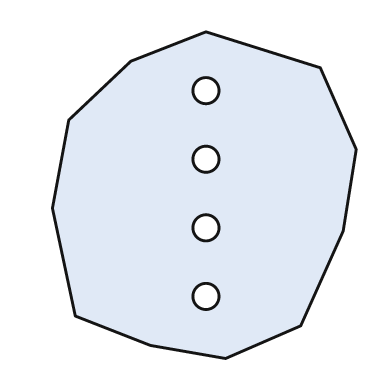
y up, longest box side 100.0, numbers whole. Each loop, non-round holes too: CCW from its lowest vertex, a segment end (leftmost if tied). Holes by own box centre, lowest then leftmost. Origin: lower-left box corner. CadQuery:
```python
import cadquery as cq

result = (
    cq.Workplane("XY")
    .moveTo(53.0, 0.0)
    .lineTo(76.0, 10.0)
    .lineTo(89.0, 39.0)
    .lineTo(93.0, 64.0)
    .lineTo(82.0, 89.0)
    .lineTo(47.0, 100.0)
    .lineTo(24.0, 91.0)
    .lineTo(5.0, 73.0)
    .lineTo(0.0, 46.0)
    .lineTo(7.0, 13.0)
    .lineTo(30.0, 4.0)
    .close()
    .moveTo(47.0, 19.0)
    .circle(4.0)
    .moveTo(47.0, 40.0)
    .circle(4.0)
    .moveTo(47.0, 61.0)
    .circle(4.0)
    .moveTo(47.0, 82.0)
    .circle(4.0)
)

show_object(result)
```